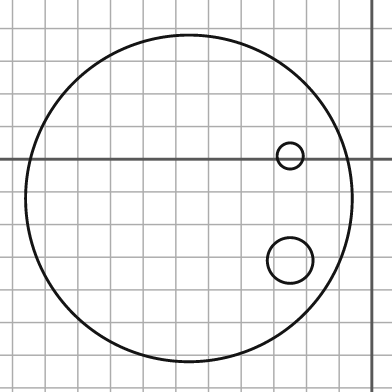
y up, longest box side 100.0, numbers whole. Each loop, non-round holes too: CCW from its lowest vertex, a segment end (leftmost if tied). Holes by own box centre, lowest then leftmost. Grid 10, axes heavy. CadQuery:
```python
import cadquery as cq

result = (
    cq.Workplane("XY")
    .moveTo(-56.0, -12.0)
    .circle(50.0)
    .moveTo(-25.0, -31.0)
    .circle(7.0)
    .moveTo(-25.0, 1.0)
    .circle(4.0)
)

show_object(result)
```